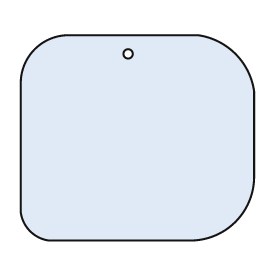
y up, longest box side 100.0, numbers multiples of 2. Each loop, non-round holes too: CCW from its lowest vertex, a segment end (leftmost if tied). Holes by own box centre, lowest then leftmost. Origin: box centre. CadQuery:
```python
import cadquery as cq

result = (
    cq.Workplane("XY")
    .moveTo(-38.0, -44.0)
    .lineTo(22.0, -44.0)
    .threePointArc((42.0, -36.0), (50.0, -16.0))
    .lineTo(50.0, 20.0)
    .threePointArc((42.0, 36.0), (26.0, 44.0))
    .lineTo(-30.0, 44.0)
    .threePointArc((-44.0, 38.0), (-50.0, 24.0))
    .lineTo(-50.0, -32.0)
    .threePointArc((-46.0, -40.0), (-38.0, -44.0))
    .close()
    .moveTo(-4.0, 36.0)
    .circle(2.0)
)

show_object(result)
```